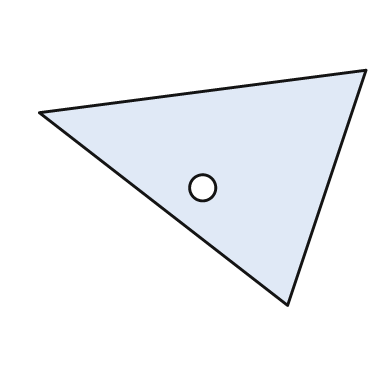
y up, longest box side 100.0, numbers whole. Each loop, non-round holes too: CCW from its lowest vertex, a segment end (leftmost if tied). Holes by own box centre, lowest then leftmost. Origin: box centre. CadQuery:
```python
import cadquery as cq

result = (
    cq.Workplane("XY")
    .moveTo(26.0, -36.0)
    .lineTo(50.0, 36.0)
    .lineTo(-50.0, 23.0)
    .close()
    .moveTo(0.0, 0.0)
    .circle(4.0)
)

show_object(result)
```